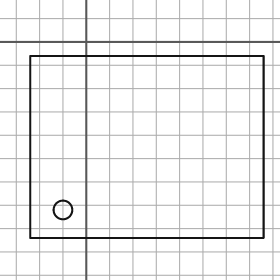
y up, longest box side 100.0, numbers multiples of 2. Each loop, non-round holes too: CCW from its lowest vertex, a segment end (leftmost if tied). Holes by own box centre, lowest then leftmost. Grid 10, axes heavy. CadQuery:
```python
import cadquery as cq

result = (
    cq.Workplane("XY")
    .moveTo(-24.0, -84.0)
    .lineTo(76.0, -84.0)
    .lineTo(76.0, -6.0)
    .lineTo(-24.0, -6.0)
    .close()
    .moveTo(-10.0, -72.0)
    .circle(4.0)
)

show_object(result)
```